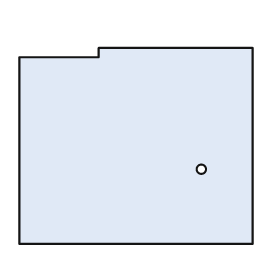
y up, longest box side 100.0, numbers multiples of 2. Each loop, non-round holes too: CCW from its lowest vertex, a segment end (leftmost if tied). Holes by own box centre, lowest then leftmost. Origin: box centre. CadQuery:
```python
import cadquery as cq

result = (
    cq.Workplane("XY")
    .moveTo(-50.0, -42.0)
    .lineTo(50.0, -42.0)
    .lineTo(50.0, 42.0)
    .lineTo(-16.0, 42.0)
    .lineTo(-16.0, 38.0)
    .lineTo(-50.0, 38.0)
    .close()
    .moveTo(28.0, -10.0)
    .circle(2.0)
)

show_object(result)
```